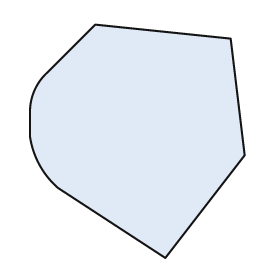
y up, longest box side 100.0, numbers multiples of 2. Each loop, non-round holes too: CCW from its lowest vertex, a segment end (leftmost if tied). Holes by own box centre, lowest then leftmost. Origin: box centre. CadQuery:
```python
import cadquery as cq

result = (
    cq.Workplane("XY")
    .moveTo(12.0, -50.0)
    .lineTo(46.0, -6.0)
    .lineTo(40.0, 44.0)
    .lineTo(-18.0, 50.0)
    .lineTo(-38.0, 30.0)
    .threePointArc((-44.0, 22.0), (-46.0, 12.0))
    .lineTo(-46.0, 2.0)
    .threePointArc((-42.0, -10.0), (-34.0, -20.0))
    .close()
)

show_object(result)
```